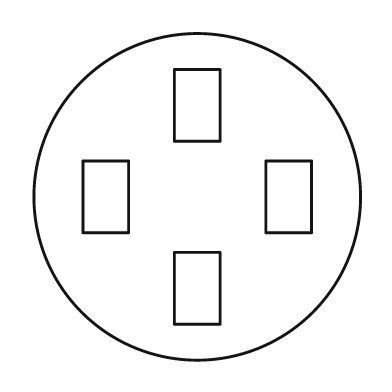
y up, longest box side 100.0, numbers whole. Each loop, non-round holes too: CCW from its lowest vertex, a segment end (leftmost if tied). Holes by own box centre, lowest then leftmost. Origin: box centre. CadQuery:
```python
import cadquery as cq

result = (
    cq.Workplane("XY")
    .moveTo(0.0, 0.0)
    .circle(50.0)
    .moveTo(-7.0, -39.0)
    .lineTo(7.0, -39.0)
    .lineTo(7.0, -17.0)
    .lineTo(-7.0, -17.0)
    .close()
    .moveTo(-35.0, -11.0)
    .lineTo(-21.0, -11.0)
    .lineTo(-21.0, 11.0)
    .lineTo(-35.0, 11.0)
    .close()
    .moveTo(21.0, -11.0)
    .lineTo(35.0, -11.0)
    .lineTo(35.0, 11.0)
    .lineTo(21.0, 11.0)
    .close()
    .moveTo(-7.0, 17.0)
    .lineTo(7.0, 17.0)
    .lineTo(7.0, 39.0)
    .lineTo(-7.0, 39.0)
    .close()
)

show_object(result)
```